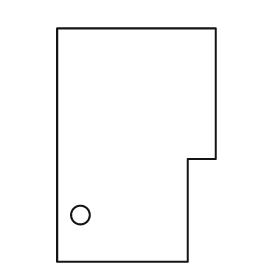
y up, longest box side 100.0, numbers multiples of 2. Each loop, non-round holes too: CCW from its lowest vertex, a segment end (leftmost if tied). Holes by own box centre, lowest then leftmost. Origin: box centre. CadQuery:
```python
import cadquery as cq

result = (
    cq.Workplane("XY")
    .moveTo(-34.0, -50.0)
    .lineTo(22.0, -50.0)
    .lineTo(22.0, -6.0)
    .lineTo(34.0, -6.0)
    .lineTo(34.0, 50.0)
    .lineTo(-34.0, 50.0)
    .close()
    .moveTo(-24.0, -30.0)
    .circle(4.0)
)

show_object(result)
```